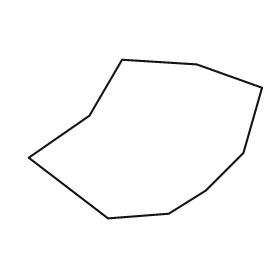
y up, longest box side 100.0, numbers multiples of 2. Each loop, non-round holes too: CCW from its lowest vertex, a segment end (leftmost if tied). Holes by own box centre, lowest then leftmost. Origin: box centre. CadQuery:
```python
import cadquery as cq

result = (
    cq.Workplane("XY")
    .moveTo(-16.0, -34.0)
    .lineTo(10.0, -32.0)
    .lineTo(26.0, -22.0)
    .lineTo(42.0, -6.0)
    .lineTo(50.0, 22.0)
    .lineTo(22.0, 32.0)
    .lineTo(-10.0, 34.0)
    .lineTo(-24.0, 10.0)
    .lineTo(-50.0, -8.0)
    .close()
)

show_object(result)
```